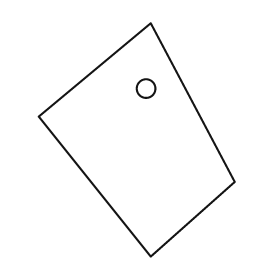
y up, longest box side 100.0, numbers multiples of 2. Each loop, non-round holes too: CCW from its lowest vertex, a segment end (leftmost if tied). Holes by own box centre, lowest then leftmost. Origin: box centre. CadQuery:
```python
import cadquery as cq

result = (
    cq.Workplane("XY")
    .moveTo(6.0, -50.0)
    .lineTo(42.0, -18.0)
    .lineTo(6.0, 50.0)
    .lineTo(-42.0, 10.0)
    .close()
    .moveTo(4.0, 22.0)
    .circle(4.0)
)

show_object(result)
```